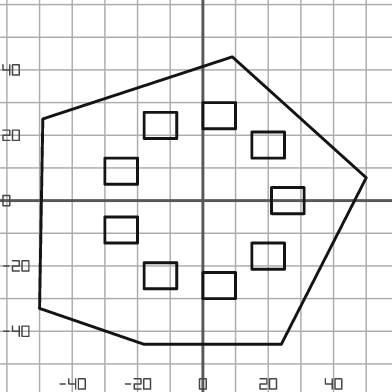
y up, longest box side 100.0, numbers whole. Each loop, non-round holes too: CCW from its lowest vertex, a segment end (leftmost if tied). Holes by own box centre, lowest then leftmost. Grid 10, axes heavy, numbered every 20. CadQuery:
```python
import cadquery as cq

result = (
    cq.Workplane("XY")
    .moveTo(-18.0, -44.0)
    .lineTo(24.0, -44.0)
    .lineTo(50.0, 7.0)
    .lineTo(9.0, 44.0)
    .lineTo(-49.0, 25.0)
    .lineTo(-50.0, -33.0)
    .close()
    .moveTo(0.0, -30.0)
    .lineTo(10.0, -30.0)
    .lineTo(10.0, -22.0)
    .lineTo(0.0, -22.0)
    .close()
    .moveTo(-18.0, -27.0)
    .lineTo(-8.0, -27.0)
    .lineTo(-8.0, -19.0)
    .lineTo(-18.0, -19.0)
    .close()
    .moveTo(15.0, -21.0)
    .lineTo(25.0, -21.0)
    .lineTo(25.0, -13.0)
    .lineTo(15.0, -13.0)
    .close()
    .moveTo(-30.0, -13.0)
    .lineTo(-20.0, -13.0)
    .lineTo(-20.0, -5.0)
    .lineTo(-30.0, -5.0)
    .close()
    .moveTo(21.0, -4.0)
    .lineTo(31.0, -4.0)
    .lineTo(31.0, 4.0)
    .lineTo(21.0, 4.0)
    .close()
    .moveTo(-30.0, 5.0)
    .lineTo(-20.0, 5.0)
    .lineTo(-20.0, 13.0)
    .lineTo(-30.0, 13.0)
    .close()
    .moveTo(15.0, 13.0)
    .lineTo(25.0, 13.0)
    .lineTo(25.0, 21.0)
    .lineTo(15.0, 21.0)
    .close()
    .moveTo(-18.0, 19.0)
    .lineTo(-8.0, 19.0)
    .lineTo(-8.0, 27.0)
    .lineTo(-18.0, 27.0)
    .close()
    .moveTo(0.0, 22.0)
    .lineTo(10.0, 22.0)
    .lineTo(10.0, 30.0)
    .lineTo(0.0, 30.0)
    .close()
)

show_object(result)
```